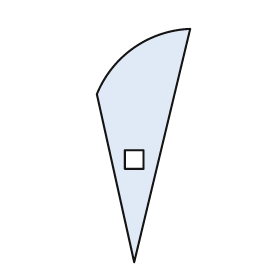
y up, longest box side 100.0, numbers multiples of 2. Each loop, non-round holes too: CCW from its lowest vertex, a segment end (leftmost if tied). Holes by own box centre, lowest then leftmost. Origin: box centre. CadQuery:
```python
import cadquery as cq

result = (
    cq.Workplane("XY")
    .moveTo(-4.0, -50.0)
    .lineTo(20.0, 50.0)
    .threePointArc((-4.0, 42.0), (-20.0, 22.0))
    .close()
    .moveTo(-8.0, -10.0)
    .lineTo(0.0, -10.0)
    .lineTo(0.0, -2.0)
    .lineTo(-8.0, -2.0)
    .close()
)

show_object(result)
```